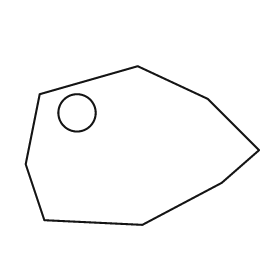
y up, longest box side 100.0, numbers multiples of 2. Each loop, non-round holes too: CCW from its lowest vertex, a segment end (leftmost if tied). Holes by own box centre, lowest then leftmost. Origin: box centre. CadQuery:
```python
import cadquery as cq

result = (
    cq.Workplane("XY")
    .moveTo(0.0, -34.0)
    .lineTo(34.0, -16.0)
    .lineTo(50.0, -2.0)
    .lineTo(28.0, 20.0)
    .lineTo(-2.0, 34.0)
    .lineTo(-44.0, 22.0)
    .lineTo(-50.0, -8.0)
    .lineTo(-42.0, -32.0)
    .close()
    .moveTo(-28.0, 14.0)
    .circle(8.0)
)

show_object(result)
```